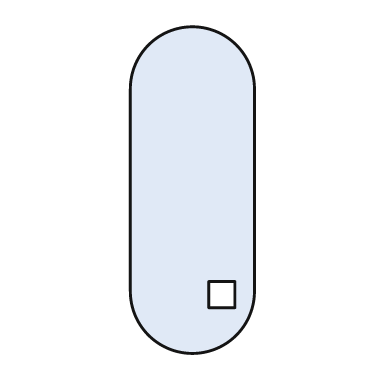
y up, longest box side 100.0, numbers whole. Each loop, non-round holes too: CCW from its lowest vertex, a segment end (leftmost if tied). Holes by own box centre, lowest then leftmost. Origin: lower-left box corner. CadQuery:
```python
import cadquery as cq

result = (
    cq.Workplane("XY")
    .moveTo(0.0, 19.0)
    .threePointArc((19.0, 0.0), (38.0, 19.0))
    .lineTo(38.0, 81.0)
    .threePointArc((19.0, 100.0), (0.0, 81.0))
    .close()
    .moveTo(24.0, 14.0)
    .lineTo(32.0, 14.0)
    .lineTo(32.0, 22.0)
    .lineTo(24.0, 22.0)
    .close()
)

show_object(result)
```